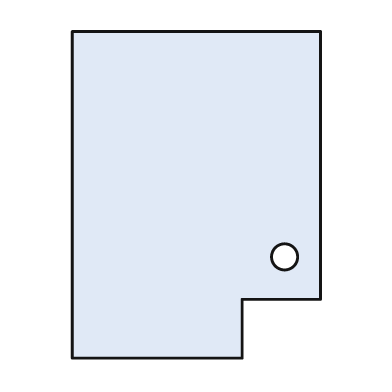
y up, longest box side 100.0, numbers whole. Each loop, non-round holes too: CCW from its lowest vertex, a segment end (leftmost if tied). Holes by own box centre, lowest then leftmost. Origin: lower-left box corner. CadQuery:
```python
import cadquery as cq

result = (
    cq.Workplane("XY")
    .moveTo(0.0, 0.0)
    .lineTo(52.0, 0.0)
    .lineTo(52.0, 18.0)
    .lineTo(76.0, 18.0)
    .lineTo(76.0, 100.0)
    .lineTo(0.0, 100.0)
    .close()
    .moveTo(65.0, 31.0)
    .circle(4.0)
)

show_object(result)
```